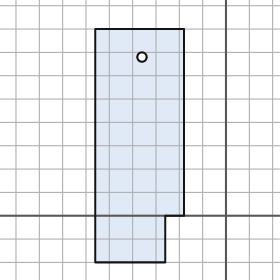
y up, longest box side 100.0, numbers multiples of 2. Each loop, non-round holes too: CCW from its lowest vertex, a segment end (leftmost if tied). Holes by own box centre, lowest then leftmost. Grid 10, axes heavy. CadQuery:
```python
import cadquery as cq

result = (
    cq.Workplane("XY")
    .moveTo(-56.0, -20.0)
    .lineTo(-26.0, -20.0)
    .lineTo(-26.0, 0.0)
    .lineTo(-18.0, 0.0)
    .lineTo(-18.0, 80.0)
    .lineTo(-56.0, 80.0)
    .close()
    .moveTo(-36.0, 68.0)
    .circle(2.0)
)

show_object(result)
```